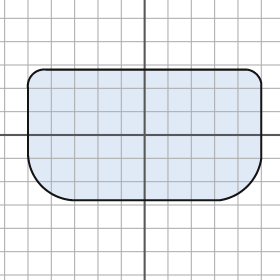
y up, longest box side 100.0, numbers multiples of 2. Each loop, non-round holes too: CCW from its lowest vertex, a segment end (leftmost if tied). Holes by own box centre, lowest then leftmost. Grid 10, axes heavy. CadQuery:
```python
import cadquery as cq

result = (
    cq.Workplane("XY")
    .moveTo(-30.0, -28.0)
    .lineTo(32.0, -28.0)
    .threePointArc((44.0, -22.0), (50.0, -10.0))
    .lineTo(50.0, 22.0)
    .threePointArc((48.0, 26.0), (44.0, 28.0))
    .lineTo(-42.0, 28.0)
    .threePointArc((-48.0, 26.0), (-50.0, 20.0))
    .lineTo(-50.0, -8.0)
    .threePointArc((-44.0, -22.0), (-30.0, -28.0))
    .close()
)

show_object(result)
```